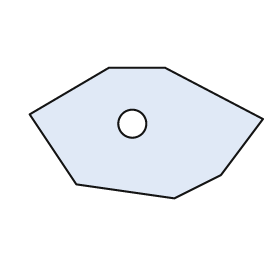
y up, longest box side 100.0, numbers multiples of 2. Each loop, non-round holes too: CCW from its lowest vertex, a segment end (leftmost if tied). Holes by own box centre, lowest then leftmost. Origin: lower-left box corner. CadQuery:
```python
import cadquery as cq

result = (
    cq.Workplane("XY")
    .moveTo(62.0, 0.0)
    .lineTo(82.0, 10.0)
    .lineTo(100.0, 34.0)
    .lineTo(58.0, 56.0)
    .lineTo(34.0, 56.0)
    .lineTo(0.0, 36.0)
    .lineTo(20.0, 6.0)
    .close()
    .moveTo(44.0, 32.0)
    .circle(6.0)
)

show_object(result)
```